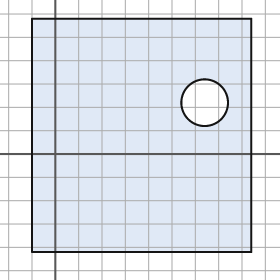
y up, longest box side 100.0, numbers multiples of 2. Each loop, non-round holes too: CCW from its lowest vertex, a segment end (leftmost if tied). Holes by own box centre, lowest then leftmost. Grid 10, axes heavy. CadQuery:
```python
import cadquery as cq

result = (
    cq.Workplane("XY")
    .moveTo(-10.0, -42.0)
    .lineTo(84.0, -42.0)
    .lineTo(84.0, 58.0)
    .lineTo(-10.0, 58.0)
    .close()
    .moveTo(64.0, 22.0)
    .circle(10.0)
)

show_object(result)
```